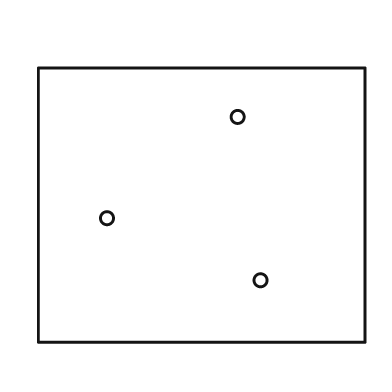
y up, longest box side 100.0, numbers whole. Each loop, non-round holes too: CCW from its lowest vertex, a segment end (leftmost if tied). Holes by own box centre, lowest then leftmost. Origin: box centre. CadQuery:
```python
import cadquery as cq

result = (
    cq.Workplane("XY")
    .moveTo(-50.0, -42.0)
    .lineTo(50.0, -42.0)
    .lineTo(50.0, 42.0)
    .lineTo(-50.0, 42.0)
    .close()
    .moveTo(18.0, -23.0)
    .circle(2.0)
    .moveTo(-29.0, -4.0)
    .circle(2.0)
    .moveTo(11.0, 27.0)
    .circle(2.0)
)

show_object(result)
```